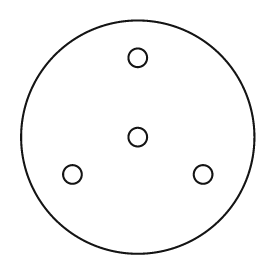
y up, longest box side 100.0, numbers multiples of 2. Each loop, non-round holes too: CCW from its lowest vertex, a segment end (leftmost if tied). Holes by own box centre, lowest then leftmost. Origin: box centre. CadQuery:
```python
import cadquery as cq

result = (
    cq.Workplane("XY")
    .moveTo(0.0, 0.0)
    .circle(50.0)
    .moveTo(-28.0, -16.0)
    .circle(4.0)
    .moveTo(28.0, -16.0)
    .circle(4.0)
    .moveTo(0.0, 0.0)
    .circle(4.0)
    .moveTo(0.0, 34.0)
    .circle(4.0)
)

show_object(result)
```